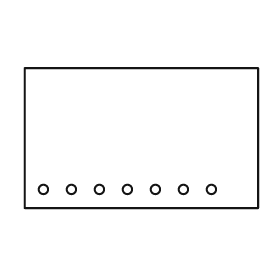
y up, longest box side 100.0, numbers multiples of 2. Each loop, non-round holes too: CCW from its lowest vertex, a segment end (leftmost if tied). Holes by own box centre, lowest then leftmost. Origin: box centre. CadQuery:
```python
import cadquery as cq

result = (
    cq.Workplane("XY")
    .moveTo(-50.0, -30.0)
    .lineTo(50.0, -30.0)
    .lineTo(50.0, 30.0)
    .lineTo(-50.0, 30.0)
    .close()
    .moveTo(-42.0, -22.0)
    .circle(2.0)
    .moveTo(-30.0, -22.0)
    .circle(2.0)
    .moveTo(-18.0, -22.0)
    .circle(2.0)
    .moveTo(-6.0, -22.0)
    .circle(2.0)
    .moveTo(6.0, -22.0)
    .circle(2.0)
    .moveTo(18.0, -22.0)
    .circle(2.0)
    .moveTo(30.0, -22.0)
    .circle(2.0)
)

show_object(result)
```